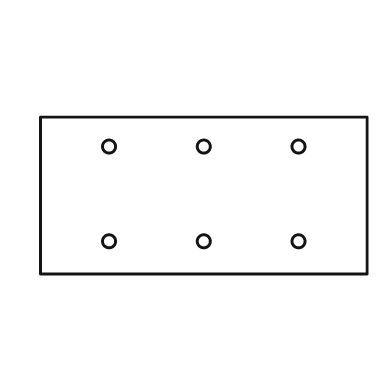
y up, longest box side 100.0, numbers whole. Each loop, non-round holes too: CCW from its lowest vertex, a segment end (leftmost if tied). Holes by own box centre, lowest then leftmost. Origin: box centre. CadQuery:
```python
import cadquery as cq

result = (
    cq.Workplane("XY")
    .moveTo(-50.0, -24.0)
    .lineTo(50.0, -24.0)
    .lineTo(50.0, 24.0)
    .lineTo(-50.0, 24.0)
    .close()
    .moveTo(-29.0, -14.0)
    .circle(2.0)
    .moveTo(0.0, -14.0)
    .circle(2.0)
    .moveTo(29.0, -14.0)
    .circle(2.0)
    .moveTo(-29.0, 15.0)
    .circle(2.0)
    .moveTo(0.0, 15.0)
    .circle(2.0)
    .moveTo(29.0, 15.0)
    .circle(2.0)
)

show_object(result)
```